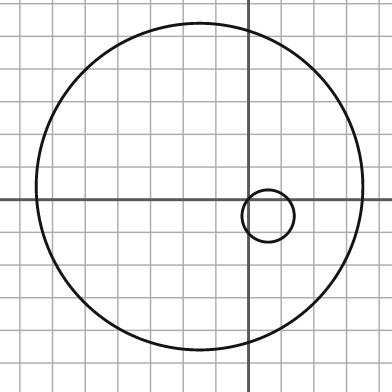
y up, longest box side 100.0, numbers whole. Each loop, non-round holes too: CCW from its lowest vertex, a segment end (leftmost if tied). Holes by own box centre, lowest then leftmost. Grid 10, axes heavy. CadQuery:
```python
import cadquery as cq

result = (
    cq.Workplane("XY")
    .moveTo(-15.0, 4.0)
    .circle(50.0)
    .moveTo(6.0, -5.0)
    .circle(8.0)
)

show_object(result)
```